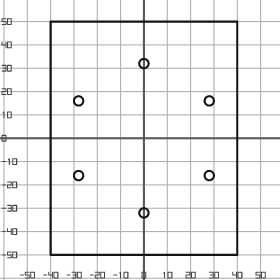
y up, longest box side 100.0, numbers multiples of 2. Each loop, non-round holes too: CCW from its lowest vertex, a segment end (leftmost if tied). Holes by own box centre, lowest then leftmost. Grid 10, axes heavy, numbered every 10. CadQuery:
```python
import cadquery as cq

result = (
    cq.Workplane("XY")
    .moveTo(-40.0, -50.0)
    .lineTo(40.0, -50.0)
    .lineTo(40.0, 50.0)
    .lineTo(-40.0, 50.0)
    .close()
    .moveTo(0.0, -32.0)
    .circle(2.0)
    .moveTo(-28.0, -16.0)
    .circle(2.0)
    .moveTo(28.0, -16.0)
    .circle(2.0)
    .moveTo(-28.0, 16.0)
    .circle(2.0)
    .moveTo(28.0, 16.0)
    .circle(2.0)
    .moveTo(0.0, 32.0)
    .circle(2.0)
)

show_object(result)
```